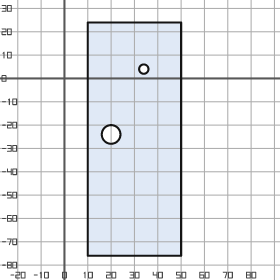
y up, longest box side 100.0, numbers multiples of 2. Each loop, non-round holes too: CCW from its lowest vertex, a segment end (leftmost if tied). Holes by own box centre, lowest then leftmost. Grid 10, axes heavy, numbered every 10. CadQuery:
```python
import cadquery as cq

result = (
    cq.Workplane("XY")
    .moveTo(10.0, -76.0)
    .lineTo(50.0, -76.0)
    .lineTo(50.0, 24.0)
    .lineTo(10.0, 24.0)
    .close()
    .moveTo(20.0, -24.0)
    .circle(4.0)
    .moveTo(34.0, 4.0)
    .circle(2.0)
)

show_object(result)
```